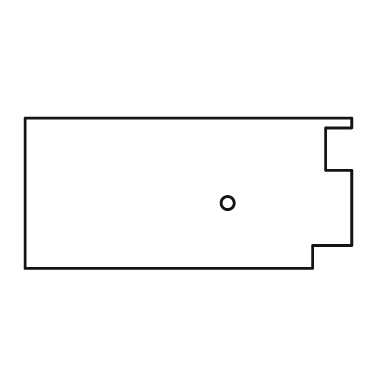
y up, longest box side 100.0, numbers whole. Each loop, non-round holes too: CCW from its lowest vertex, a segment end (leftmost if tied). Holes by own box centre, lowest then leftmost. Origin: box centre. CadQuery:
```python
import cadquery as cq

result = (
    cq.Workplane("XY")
    .moveTo(-50.0, -23.0)
    .lineTo(38.0, -23.0)
    .lineTo(38.0, -16.0)
    .lineTo(50.0, -16.0)
    .lineTo(50.0, 7.0)
    .lineTo(42.0, 7.0)
    .lineTo(42.0, 20.0)
    .lineTo(50.0, 20.0)
    .lineTo(50.0, 23.0)
    .lineTo(-50.0, 23.0)
    .close()
    .moveTo(12.0, -3.0)
    .circle(2.0)
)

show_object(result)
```